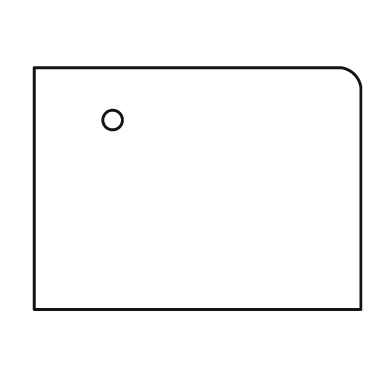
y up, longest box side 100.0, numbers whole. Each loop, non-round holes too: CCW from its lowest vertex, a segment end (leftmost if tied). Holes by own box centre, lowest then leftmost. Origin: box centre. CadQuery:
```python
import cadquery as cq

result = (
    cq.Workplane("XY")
    .moveTo(-50.0, -37.0)
    .lineTo(50.0, -37.0)
    .lineTo(50.0, 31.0)
    .threePointArc((48.0, 35.0), (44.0, 37.0))
    .lineTo(-50.0, 37.0)
    .close()
    .moveTo(-26.0, 21.0)
    .circle(3.0)
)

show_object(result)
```